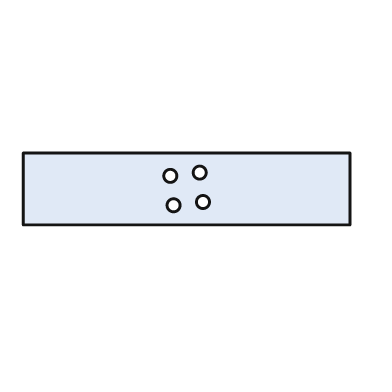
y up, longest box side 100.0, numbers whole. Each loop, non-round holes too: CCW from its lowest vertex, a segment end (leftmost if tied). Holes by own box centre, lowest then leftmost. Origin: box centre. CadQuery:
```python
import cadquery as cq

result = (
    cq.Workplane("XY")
    .moveTo(-50.0, -11.0)
    .lineTo(50.0, -11.0)
    .lineTo(50.0, 11.0)
    .lineTo(-50.0, 11.0)
    .close()
    .moveTo(-4.0, -5.0)
    .circle(2.0)
    .moveTo(5.0, -4.0)
    .circle(2.0)
    .moveTo(-5.0, 4.0)
    .circle(2.0)
    .moveTo(4.0, 5.0)
    .circle(2.0)
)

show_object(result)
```